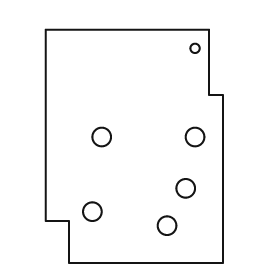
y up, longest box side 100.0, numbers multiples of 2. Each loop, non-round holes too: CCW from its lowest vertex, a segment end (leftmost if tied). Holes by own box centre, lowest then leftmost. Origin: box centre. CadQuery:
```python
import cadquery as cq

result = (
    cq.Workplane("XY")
    .moveTo(-28.0, -50.0)
    .lineTo(38.0, -50.0)
    .lineTo(38.0, 22.0)
    .lineTo(32.0, 22.0)
    .lineTo(32.0, 50.0)
    .lineTo(-38.0, 50.0)
    .lineTo(-38.0, -32.0)
    .lineTo(-28.0, -32.0)
    .close()
    .moveTo(14.0, -34.0)
    .circle(4.0)
    .moveTo(-18.0, -28.0)
    .circle(4.0)
    .moveTo(22.0, -18.0)
    .circle(4.0)
    .moveTo(-14.0, 4.0)
    .circle(4.0)
    .moveTo(26.0, 4.0)
    .circle(4.0)
    .moveTo(26.0, 42.0)
    .circle(2.0)
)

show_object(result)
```